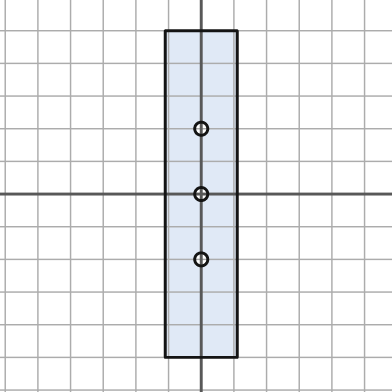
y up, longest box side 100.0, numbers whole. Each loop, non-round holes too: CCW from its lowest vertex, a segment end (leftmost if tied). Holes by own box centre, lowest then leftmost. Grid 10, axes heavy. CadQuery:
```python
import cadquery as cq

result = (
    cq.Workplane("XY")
    .moveTo(-11.0, -50.0)
    .lineTo(11.0, -50.0)
    .lineTo(11.0, 50.0)
    .lineTo(-11.0, 50.0)
    .close()
    .moveTo(0.0, -20.0)
    .circle(2.0)
    .moveTo(0.0, 0.0)
    .circle(2.0)
    .moveTo(0.0, 20.0)
    .circle(2.0)
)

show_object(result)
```